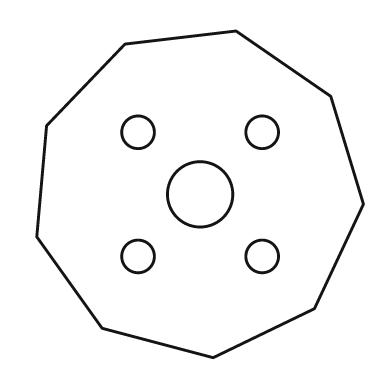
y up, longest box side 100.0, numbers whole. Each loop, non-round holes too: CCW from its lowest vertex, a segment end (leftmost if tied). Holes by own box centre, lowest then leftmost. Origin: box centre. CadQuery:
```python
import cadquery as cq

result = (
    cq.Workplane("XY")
    .moveTo(4.0, -50.0)
    .lineTo(35.0, -35.0)
    .lineTo(50.0, -3.0)
    .lineTo(40.0, 30.0)
    .lineTo(11.0, 50.0)
    .lineTo(-23.0, 46.0)
    .lineTo(-47.0, 21.0)
    .lineTo(-50.0, -13.0)
    .lineTo(-30.0, -41.0)
    .close()
    .moveTo(-19.0, -19.0)
    .circle(5.0)
    .moveTo(19.0, -19.0)
    .circle(5.0)
    .moveTo(0.0, 0.0)
    .circle(10.0)
    .moveTo(-19.0, 19.0)
    .circle(5.0)
    .moveTo(19.0, 19.0)
    .circle(5.0)
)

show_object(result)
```